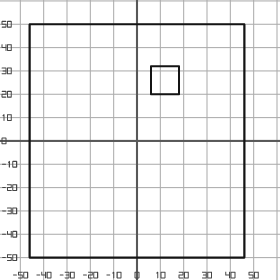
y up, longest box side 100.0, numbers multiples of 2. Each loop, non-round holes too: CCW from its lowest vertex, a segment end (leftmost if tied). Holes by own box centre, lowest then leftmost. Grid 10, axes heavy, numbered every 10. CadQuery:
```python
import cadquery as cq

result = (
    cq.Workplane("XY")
    .moveTo(-46.0, -50.0)
    .lineTo(46.0, -50.0)
    .lineTo(46.0, 50.0)
    .lineTo(-46.0, 50.0)
    .close()
    .moveTo(6.0, 20.0)
    .lineTo(18.0, 20.0)
    .lineTo(18.0, 32.0)
    .lineTo(6.0, 32.0)
    .close()
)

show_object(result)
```